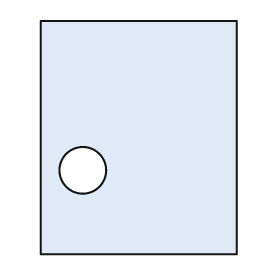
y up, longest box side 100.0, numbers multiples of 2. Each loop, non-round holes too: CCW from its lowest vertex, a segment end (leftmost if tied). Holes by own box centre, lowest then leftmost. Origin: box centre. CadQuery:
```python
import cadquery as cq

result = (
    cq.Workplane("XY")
    .moveTo(-42.0, -50.0)
    .lineTo(42.0, -50.0)
    .lineTo(42.0, 50.0)
    .lineTo(-42.0, 50.0)
    .close()
    .moveTo(-24.0, -14.0)
    .circle(10.0)
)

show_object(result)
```